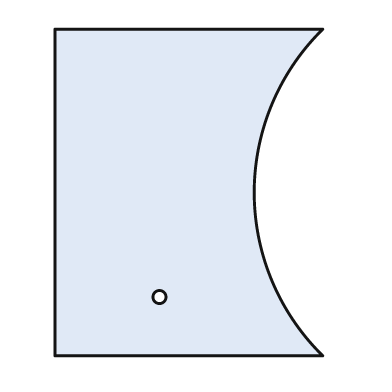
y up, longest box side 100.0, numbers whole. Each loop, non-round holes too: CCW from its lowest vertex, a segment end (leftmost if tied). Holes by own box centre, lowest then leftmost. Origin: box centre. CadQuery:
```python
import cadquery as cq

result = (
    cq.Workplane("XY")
    .moveTo(-41.0, -50.0)
    .lineTo(41.0, -50.0)
    .threePointArc((20.0, 0.0), (41.0, 50.0))
    .lineTo(-41.0, 50.0)
    .close()
    .moveTo(-9.0, -32.0)
    .circle(2.0)
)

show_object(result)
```